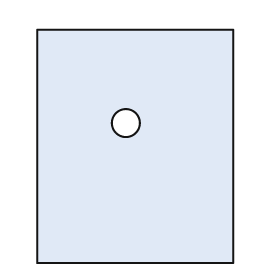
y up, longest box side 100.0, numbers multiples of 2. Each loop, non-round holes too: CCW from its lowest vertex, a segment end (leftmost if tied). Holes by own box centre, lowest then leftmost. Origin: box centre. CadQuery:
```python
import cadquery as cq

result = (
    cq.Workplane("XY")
    .moveTo(-42.0, -50.0)
    .lineTo(42.0, -50.0)
    .lineTo(42.0, 50.0)
    .lineTo(-42.0, 50.0)
    .close()
    .moveTo(-4.0, 10.0)
    .circle(6.0)
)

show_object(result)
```